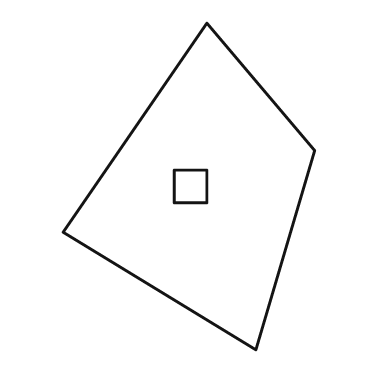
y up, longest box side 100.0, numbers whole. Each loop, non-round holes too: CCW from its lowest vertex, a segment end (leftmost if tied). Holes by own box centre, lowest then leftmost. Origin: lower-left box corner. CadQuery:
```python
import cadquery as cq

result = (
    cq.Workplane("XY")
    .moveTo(59.0, 0.0)
    .lineTo(77.0, 61.0)
    .lineTo(44.0, 100.0)
    .lineTo(0.0, 36.0)
    .close()
    .moveTo(34.0, 45.0)
    .lineTo(44.0, 45.0)
    .lineTo(44.0, 55.0)
    .lineTo(34.0, 55.0)
    .close()
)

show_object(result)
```